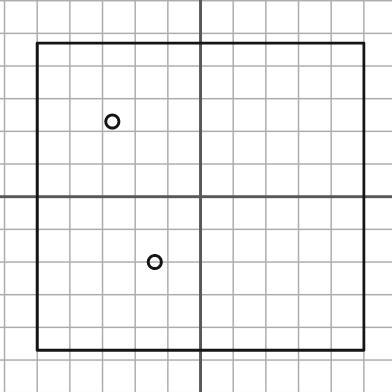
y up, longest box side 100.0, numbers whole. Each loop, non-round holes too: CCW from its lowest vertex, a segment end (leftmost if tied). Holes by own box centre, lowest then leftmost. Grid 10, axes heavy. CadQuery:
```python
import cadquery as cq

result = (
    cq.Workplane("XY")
    .moveTo(-50.0, -47.0)
    .lineTo(50.0, -47.0)
    .lineTo(50.0, 47.0)
    .lineTo(-50.0, 47.0)
    .close()
    .moveTo(-14.0, -20.0)
    .circle(2.0)
    .moveTo(-27.0, 23.0)
    .circle(2.0)
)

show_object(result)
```